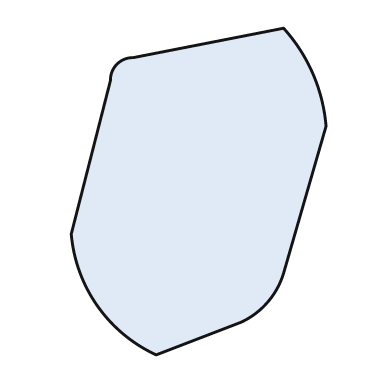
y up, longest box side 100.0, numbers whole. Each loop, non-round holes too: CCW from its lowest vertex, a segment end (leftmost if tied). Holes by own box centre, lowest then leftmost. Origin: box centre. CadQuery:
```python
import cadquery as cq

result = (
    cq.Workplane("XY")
    .moveTo(-13.0, -50.0)
    .lineTo(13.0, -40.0)
    .threePointArc((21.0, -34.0), (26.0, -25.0))
    .lineTo(39.0, 20.0)
    .threePointArc((35.0, 36.0), (26.0, 50.0))
    .lineTo(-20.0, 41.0)
    .threePointArc((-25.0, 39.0), (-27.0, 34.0))
    .lineTo(-39.0, -13.0)
    .threePointArc((-31.0, -35.0), (-13.0, -50.0))
    .close()
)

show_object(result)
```